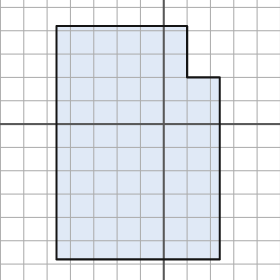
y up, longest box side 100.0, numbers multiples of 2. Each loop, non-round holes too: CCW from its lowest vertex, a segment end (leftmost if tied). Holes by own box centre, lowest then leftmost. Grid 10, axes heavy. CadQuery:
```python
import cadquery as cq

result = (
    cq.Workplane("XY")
    .moveTo(-46.0, -58.0)
    .lineTo(24.0, -58.0)
    .lineTo(24.0, 20.0)
    .lineTo(10.0, 20.0)
    .lineTo(10.0, 42.0)
    .lineTo(-46.0, 42.0)
    .close()
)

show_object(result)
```